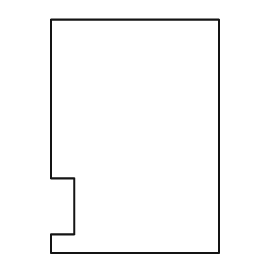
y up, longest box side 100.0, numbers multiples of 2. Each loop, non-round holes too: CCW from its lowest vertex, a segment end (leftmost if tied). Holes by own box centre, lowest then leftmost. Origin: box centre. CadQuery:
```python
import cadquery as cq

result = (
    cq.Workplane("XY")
    .moveTo(-36.0, -50.0)
    .lineTo(36.0, -50.0)
    .lineTo(36.0, 50.0)
    .lineTo(-36.0, 50.0)
    .lineTo(-36.0, -18.0)
    .lineTo(-26.0, -18.0)
    .lineTo(-26.0, -42.0)
    .lineTo(-36.0, -42.0)
    .close()
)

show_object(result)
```